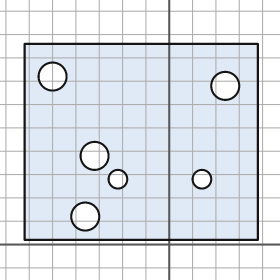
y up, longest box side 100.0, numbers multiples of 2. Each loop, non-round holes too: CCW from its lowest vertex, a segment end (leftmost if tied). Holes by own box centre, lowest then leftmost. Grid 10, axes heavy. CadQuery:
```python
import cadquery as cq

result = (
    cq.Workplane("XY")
    .moveTo(-62.0, 2.0)
    .lineTo(38.0, 2.0)
    .lineTo(38.0, 86.0)
    .lineTo(-62.0, 86.0)
    .close()
    .moveTo(-36.0, 12.0)
    .circle(6.0)
    .moveTo(-22.0, 28.0)
    .circle(4.0)
    .moveTo(14.0, 28.0)
    .circle(4.0)
    .moveTo(-32.0, 38.0)
    .circle(6.0)
    .moveTo(24.0, 68.0)
    .circle(6.0)
    .moveTo(-50.0, 72.0)
    .circle(6.0)
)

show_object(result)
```